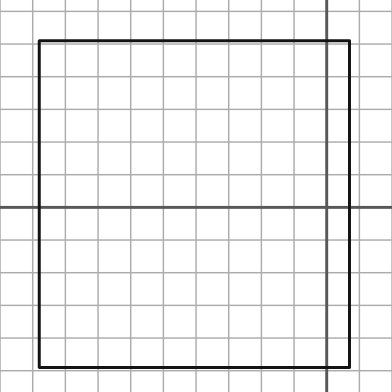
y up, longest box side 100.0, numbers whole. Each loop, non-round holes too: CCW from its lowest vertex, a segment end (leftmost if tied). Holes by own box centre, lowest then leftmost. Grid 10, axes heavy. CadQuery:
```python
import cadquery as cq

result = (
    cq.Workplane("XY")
    .moveTo(-88.0, -49.0)
    .lineTo(7.0, -49.0)
    .lineTo(7.0, 51.0)
    .lineTo(-88.0, 51.0)
    .close()
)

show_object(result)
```